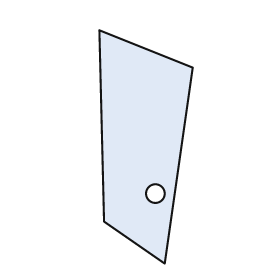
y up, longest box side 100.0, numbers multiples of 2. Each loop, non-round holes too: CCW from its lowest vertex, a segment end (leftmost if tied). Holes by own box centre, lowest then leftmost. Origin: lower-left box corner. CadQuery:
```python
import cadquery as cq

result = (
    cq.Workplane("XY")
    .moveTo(28.0, 0.0)
    .lineTo(40.0, 84.0)
    .lineTo(0.0, 100.0)
    .lineTo(2.0, 18.0)
    .close()
    .moveTo(24.0, 30.0)
    .circle(4.0)
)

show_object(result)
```